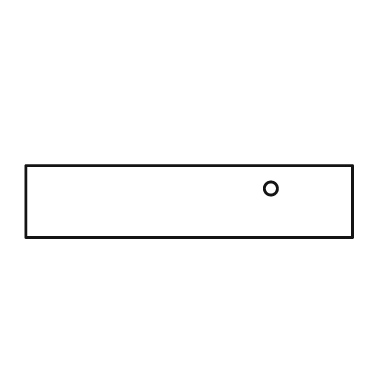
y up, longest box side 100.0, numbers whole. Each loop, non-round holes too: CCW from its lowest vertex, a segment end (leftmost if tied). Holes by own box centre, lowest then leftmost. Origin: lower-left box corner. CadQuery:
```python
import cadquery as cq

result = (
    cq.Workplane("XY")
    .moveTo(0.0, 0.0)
    .lineTo(100.0, 0.0)
    .lineTo(100.0, 22.0)
    .lineTo(0.0, 22.0)
    .close()
    .moveTo(75.0, 15.0)
    .circle(2.0)
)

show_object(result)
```